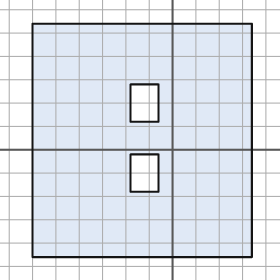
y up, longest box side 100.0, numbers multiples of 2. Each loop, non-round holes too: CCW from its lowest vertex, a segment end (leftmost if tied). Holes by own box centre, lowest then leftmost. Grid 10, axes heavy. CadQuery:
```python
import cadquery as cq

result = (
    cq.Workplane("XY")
    .moveTo(-60.0, -46.0)
    .lineTo(34.0, -46.0)
    .lineTo(34.0, 54.0)
    .lineTo(-60.0, 54.0)
    .close()
    .moveTo(-18.0, -18.0)
    .lineTo(-6.0, -18.0)
    .lineTo(-6.0, -2.0)
    .lineTo(-18.0, -2.0)
    .close()
    .moveTo(-18.0, 12.0)
    .lineTo(-6.0, 12.0)
    .lineTo(-6.0, 28.0)
    .lineTo(-18.0, 28.0)
    .close()
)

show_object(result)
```